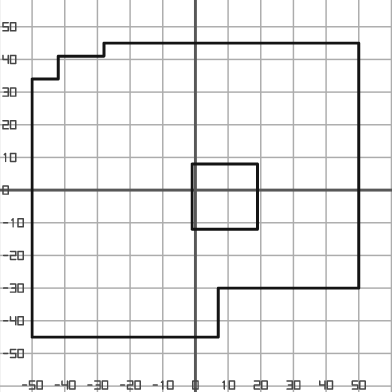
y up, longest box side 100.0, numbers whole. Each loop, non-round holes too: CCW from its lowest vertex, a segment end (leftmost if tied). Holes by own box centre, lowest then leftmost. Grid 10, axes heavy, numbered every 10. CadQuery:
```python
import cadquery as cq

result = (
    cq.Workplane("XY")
    .moveTo(-50.0, -45.0)
    .lineTo(7.0, -45.0)
    .lineTo(7.0, -30.0)
    .lineTo(50.0, -30.0)
    .lineTo(50.0, 45.0)
    .lineTo(-28.0, 45.0)
    .lineTo(-28.0, 41.0)
    .lineTo(-42.0, 41.0)
    .lineTo(-42.0, 34.0)
    .lineTo(-50.0, 34.0)
    .close()
    .moveTo(-1.0, -12.0)
    .lineTo(19.0, -12.0)
    .lineTo(19.0, 8.0)
    .lineTo(-1.0, 8.0)
    .close()
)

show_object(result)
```